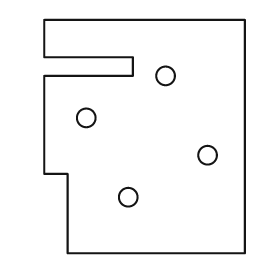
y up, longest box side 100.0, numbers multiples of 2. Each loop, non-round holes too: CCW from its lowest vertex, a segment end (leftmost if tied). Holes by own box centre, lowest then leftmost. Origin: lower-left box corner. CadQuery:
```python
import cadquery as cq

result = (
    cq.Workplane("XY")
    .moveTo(10.0, 0.0)
    .lineTo(86.0, 0.0)
    .lineTo(86.0, 100.0)
    .lineTo(0.0, 100.0)
    .lineTo(0.0, 84.0)
    .lineTo(38.0, 84.0)
    .lineTo(38.0, 76.0)
    .lineTo(0.0, 76.0)
    .lineTo(0.0, 34.0)
    .lineTo(10.0, 34.0)
    .close()
    .moveTo(36.0, 24.0)
    .circle(4.0)
    .moveTo(70.0, 42.0)
    .circle(4.0)
    .moveTo(18.0, 58.0)
    .circle(4.0)
    .moveTo(52.0, 76.0)
    .circle(4.0)
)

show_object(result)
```